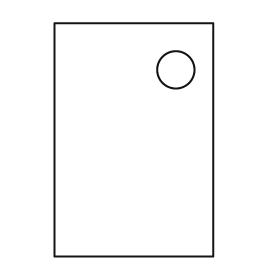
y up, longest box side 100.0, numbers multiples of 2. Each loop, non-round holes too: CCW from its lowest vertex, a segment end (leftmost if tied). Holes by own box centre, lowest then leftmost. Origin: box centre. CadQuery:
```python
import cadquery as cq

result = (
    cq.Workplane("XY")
    .moveTo(-34.0, -50.0)
    .lineTo(34.0, -50.0)
    .lineTo(34.0, 50.0)
    .lineTo(-34.0, 50.0)
    .close()
    .moveTo(18.0, 30.0)
    .circle(8.0)
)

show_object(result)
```